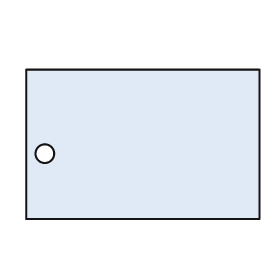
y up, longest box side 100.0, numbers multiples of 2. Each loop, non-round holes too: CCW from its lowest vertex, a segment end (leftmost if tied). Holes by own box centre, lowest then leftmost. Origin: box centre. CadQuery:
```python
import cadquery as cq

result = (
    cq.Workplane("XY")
    .moveTo(-50.0, -32.0)
    .lineTo(50.0, -32.0)
    .lineTo(50.0, 32.0)
    .lineTo(-50.0, 32.0)
    .close()
    .moveTo(-42.0, -4.0)
    .circle(4.0)
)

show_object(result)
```